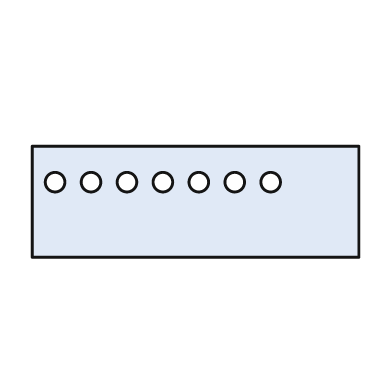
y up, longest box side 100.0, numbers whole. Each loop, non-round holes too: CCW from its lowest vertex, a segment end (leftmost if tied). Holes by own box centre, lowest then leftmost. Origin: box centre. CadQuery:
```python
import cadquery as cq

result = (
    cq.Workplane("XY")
    .moveTo(-50.0, -17.0)
    .lineTo(50.0, -17.0)
    .lineTo(50.0, 17.0)
    .lineTo(-50.0, 17.0)
    .close()
    .moveTo(-43.0, 6.0)
    .circle(3.0)
    .moveTo(-32.0, 6.0)
    .circle(3.0)
    .moveTo(-21.0, 6.0)
    .circle(3.0)
    .moveTo(-10.0, 6.0)
    .circle(3.0)
    .moveTo(1.0, 6.0)
    .circle(3.0)
    .moveTo(12.0, 6.0)
    .circle(3.0)
    .moveTo(23.0, 6.0)
    .circle(3.0)
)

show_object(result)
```